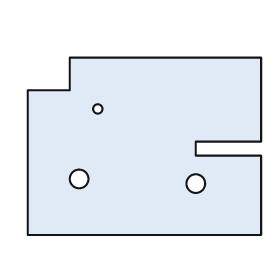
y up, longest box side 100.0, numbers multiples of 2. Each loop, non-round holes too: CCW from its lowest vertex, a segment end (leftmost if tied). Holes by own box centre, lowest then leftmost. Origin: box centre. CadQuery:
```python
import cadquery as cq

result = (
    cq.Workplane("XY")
    .moveTo(-50.0, -38.0)
    .lineTo(50.0, -38.0)
    .lineTo(50.0, -4.0)
    .lineTo(22.0, -4.0)
    .lineTo(22.0, 2.0)
    .lineTo(50.0, 2.0)
    .lineTo(50.0, 38.0)
    .lineTo(-32.0, 38.0)
    .lineTo(-32.0, 24.0)
    .lineTo(-50.0, 24.0)
    .close()
    .moveTo(22.0, -16.0)
    .circle(4.0)
    .moveTo(-28.0, -14.0)
    .circle(4.0)
    .moveTo(-20.0, 16.0)
    .circle(2.0)
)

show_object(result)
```